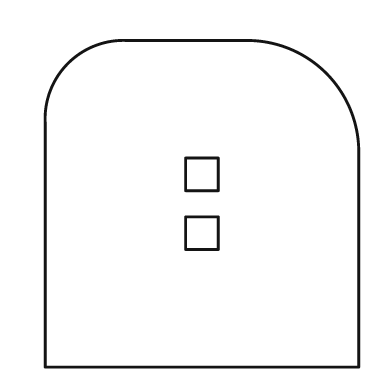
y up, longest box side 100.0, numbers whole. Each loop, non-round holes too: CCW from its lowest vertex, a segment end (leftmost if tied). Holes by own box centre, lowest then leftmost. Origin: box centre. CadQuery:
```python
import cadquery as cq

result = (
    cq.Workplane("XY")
    .moveTo(-48.0, -50.0)
    .lineTo(48.0, -50.0)
    .lineTo(48.0, 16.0)
    .threePointArc((38.0, 40.0), (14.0, 50.0))
    .lineTo(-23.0, 50.0)
    .threePointArc((-41.0, 43.0), (-48.0, 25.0))
    .close()
    .moveTo(-5.0, -14.0)
    .lineTo(5.0, -14.0)
    .lineTo(5.0, -4.0)
    .lineTo(-5.0, -4.0)
    .close()
    .moveTo(-5.0, 4.0)
    .lineTo(5.0, 4.0)
    .lineTo(5.0, 14.0)
    .lineTo(-5.0, 14.0)
    .close()
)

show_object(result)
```